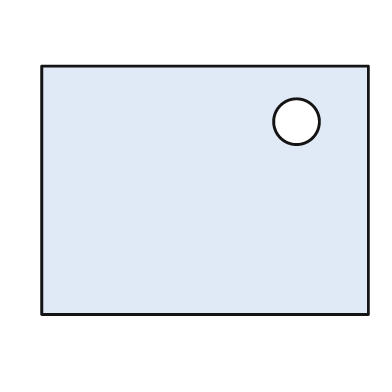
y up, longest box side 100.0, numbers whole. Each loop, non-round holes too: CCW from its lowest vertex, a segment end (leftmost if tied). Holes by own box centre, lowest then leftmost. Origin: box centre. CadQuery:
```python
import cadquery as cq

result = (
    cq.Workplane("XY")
    .moveTo(-50.0, -38.0)
    .lineTo(50.0, -38.0)
    .lineTo(50.0, 38.0)
    .lineTo(-50.0, 38.0)
    .close()
    .moveTo(28.0, 21.0)
    .circle(7.0)
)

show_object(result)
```